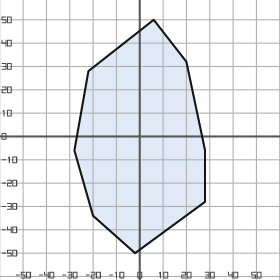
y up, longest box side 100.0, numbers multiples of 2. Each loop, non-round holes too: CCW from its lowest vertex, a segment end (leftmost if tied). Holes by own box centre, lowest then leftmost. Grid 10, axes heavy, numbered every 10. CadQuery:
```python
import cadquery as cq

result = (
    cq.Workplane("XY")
    .moveTo(-2.0, -50.0)
    .lineTo(28.0, -28.0)
    .lineTo(28.0, -6.0)
    .lineTo(20.0, 32.0)
    .lineTo(6.0, 50.0)
    .lineTo(-22.0, 28.0)
    .lineTo(-28.0, -6.0)
    .lineTo(-20.0, -34.0)
    .close()
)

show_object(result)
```